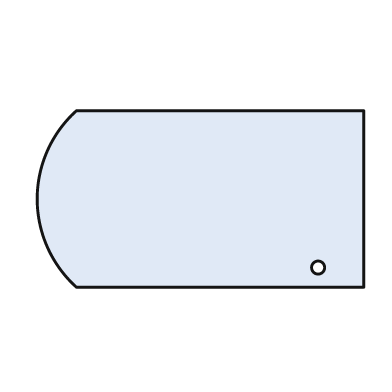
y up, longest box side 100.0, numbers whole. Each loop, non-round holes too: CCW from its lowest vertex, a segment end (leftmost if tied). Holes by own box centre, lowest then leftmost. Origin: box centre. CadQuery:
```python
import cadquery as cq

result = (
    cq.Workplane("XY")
    .moveTo(-38.0, -27.0)
    .lineTo(50.0, -27.0)
    .lineTo(50.0, 27.0)
    .lineTo(-38.0, 27.0)
    .threePointArc((-50.0, 0.0), (-38.0, -27.0))
    .close()
    .moveTo(36.0, -21.0)
    .circle(2.0)
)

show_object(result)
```